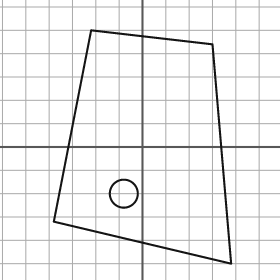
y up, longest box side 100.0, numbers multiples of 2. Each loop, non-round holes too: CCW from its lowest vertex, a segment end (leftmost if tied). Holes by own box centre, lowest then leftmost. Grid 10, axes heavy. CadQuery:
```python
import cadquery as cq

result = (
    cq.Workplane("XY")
    .moveTo(38.0, -50.0)
    .lineTo(30.0, 44.0)
    .lineTo(-22.0, 50.0)
    .lineTo(-38.0, -32.0)
    .close()
    .moveTo(-8.0, -20.0)
    .circle(6.0)
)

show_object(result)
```